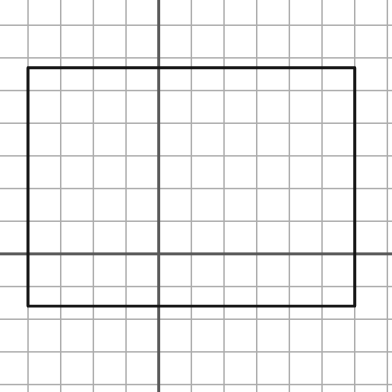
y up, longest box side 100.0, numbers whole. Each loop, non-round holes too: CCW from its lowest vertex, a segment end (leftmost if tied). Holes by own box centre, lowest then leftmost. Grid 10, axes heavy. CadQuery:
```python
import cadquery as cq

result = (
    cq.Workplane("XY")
    .moveTo(-40.0, -16.0)
    .lineTo(60.0, -16.0)
    .lineTo(60.0, 57.0)
    .lineTo(-40.0, 57.0)
    .close()
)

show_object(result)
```